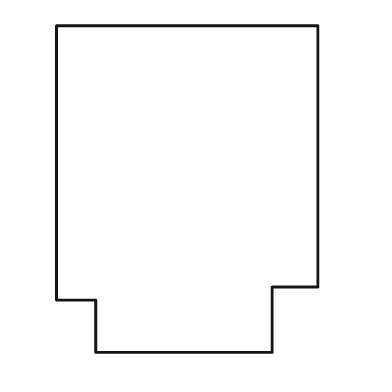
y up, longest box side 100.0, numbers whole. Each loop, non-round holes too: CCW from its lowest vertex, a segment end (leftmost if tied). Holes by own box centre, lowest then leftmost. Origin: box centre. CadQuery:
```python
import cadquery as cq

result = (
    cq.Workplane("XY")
    .moveTo(-28.0, -50.0)
    .lineTo(26.0, -50.0)
    .lineTo(26.0, -30.0)
    .lineTo(40.0, -30.0)
    .lineTo(40.0, 50.0)
    .lineTo(-40.0, 50.0)
    .lineTo(-40.0, -34.0)
    .lineTo(-28.0, -34.0)
    .close()
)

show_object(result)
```